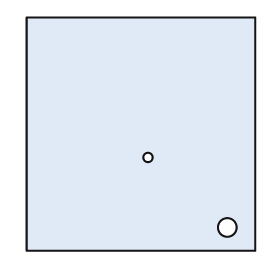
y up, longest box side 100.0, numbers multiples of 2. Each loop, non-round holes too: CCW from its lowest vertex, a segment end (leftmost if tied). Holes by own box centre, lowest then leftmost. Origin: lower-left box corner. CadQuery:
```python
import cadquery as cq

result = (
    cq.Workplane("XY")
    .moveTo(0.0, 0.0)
    .lineTo(98.0, 0.0)
    .lineTo(98.0, 100.0)
    .lineTo(0.0, 100.0)
    .close()
    .moveTo(86.0, 10.0)
    .circle(4.0)
    .moveTo(52.0, 40.0)
    .circle(2.0)
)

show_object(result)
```